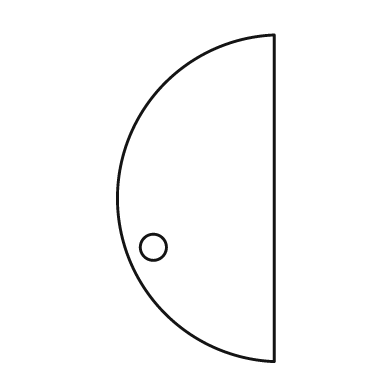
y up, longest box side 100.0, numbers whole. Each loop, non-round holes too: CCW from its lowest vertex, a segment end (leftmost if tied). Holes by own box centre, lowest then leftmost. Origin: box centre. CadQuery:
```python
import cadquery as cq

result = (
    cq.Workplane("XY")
    .moveTo(24.0, -50.0)
    .lineTo(24.0, 50.0)
    .threePointArc((-24.0, 0.0), (24.0, -50.0))
    .close()
    .moveTo(-13.0, -15.0)
    .circle(4.0)
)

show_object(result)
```